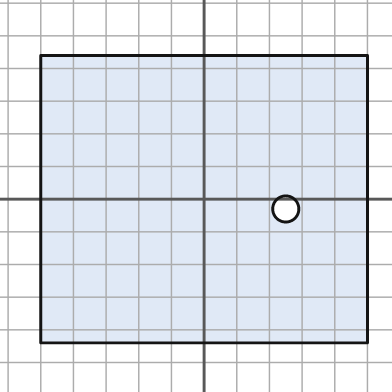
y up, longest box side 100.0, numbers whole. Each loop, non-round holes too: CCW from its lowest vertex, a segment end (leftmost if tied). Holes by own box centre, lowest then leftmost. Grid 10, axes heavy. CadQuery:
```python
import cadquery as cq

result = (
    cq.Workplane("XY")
    .moveTo(-50.0, -44.0)
    .lineTo(50.0, -44.0)
    .lineTo(50.0, 44.0)
    .lineTo(-50.0, 44.0)
    .close()
    .moveTo(25.0, -3.0)
    .circle(4.0)
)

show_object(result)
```